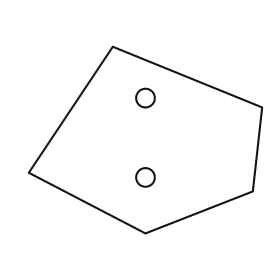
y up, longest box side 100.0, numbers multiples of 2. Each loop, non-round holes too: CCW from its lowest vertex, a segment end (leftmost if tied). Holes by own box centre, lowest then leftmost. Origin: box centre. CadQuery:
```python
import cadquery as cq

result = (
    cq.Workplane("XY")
    .moveTo(0.0, -40.0)
    .lineTo(46.0, -22.0)
    .lineTo(50.0, 14.0)
    .lineTo(-14.0, 40.0)
    .lineTo(-50.0, -14.0)
    .close()
    .moveTo(0.0, -16.0)
    .circle(4.0)
    .moveTo(0.0, 18.0)
    .circle(4.0)
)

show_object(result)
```